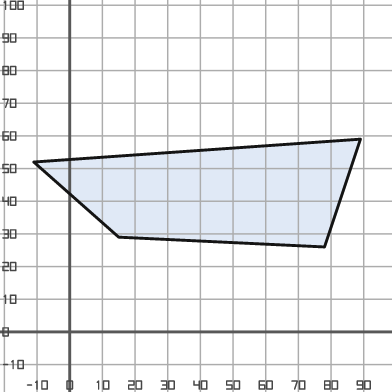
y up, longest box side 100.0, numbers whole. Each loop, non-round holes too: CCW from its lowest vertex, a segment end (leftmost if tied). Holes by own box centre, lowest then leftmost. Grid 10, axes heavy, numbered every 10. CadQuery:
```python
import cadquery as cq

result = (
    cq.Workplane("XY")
    .moveTo(78.0, 26.0)
    .lineTo(89.0, 59.0)
    .lineTo(-11.0, 52.0)
    .lineTo(15.0, 29.0)
    .close()
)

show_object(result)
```